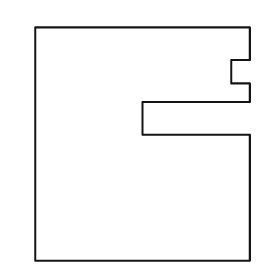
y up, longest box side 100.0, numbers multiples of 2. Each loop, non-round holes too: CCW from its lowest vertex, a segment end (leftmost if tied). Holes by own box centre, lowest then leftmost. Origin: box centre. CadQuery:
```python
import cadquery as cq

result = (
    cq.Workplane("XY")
    .moveTo(-46.0, -50.0)
    .lineTo(46.0, -50.0)
    .lineTo(46.0, 4.0)
    .lineTo(0.0, 4.0)
    .lineTo(0.0, 18.0)
    .lineTo(46.0, 18.0)
    .lineTo(46.0, 26.0)
    .lineTo(38.0, 26.0)
    .lineTo(38.0, 36.0)
    .lineTo(46.0, 36.0)
    .lineTo(46.0, 50.0)
    .lineTo(-46.0, 50.0)
    .close()
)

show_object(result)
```